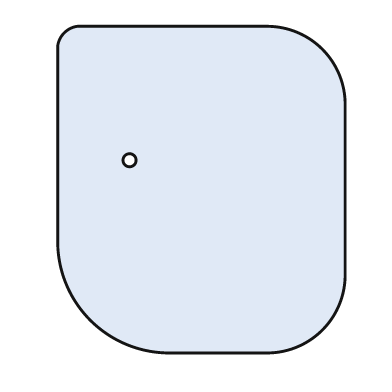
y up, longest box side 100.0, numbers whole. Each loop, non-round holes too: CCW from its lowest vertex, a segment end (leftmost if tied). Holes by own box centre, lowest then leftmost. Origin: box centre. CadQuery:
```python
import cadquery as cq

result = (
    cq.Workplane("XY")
    .moveTo(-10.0, -50.0)
    .lineTo(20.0, -50.0)
    .threePointArc((37.0, -43.0), (44.0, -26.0))
    .lineTo(44.0, 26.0)
    .threePointArc((37.0, 43.0), (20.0, 50.0))
    .lineTo(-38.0, 50.0)
    .threePointArc((-42.0, 48.0), (-44.0, 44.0))
    .lineTo(-44.0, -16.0)
    .threePointArc((-34.0, -40.0), (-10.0, -50.0))
    .close()
    .moveTo(-22.0, 9.0)
    .circle(2.0)
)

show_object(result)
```